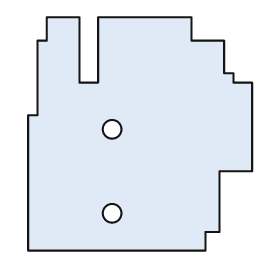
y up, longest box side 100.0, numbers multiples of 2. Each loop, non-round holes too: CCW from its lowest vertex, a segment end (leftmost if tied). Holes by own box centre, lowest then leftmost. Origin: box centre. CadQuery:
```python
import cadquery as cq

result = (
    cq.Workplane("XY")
    .moveTo(-48.0, -50.0)
    .lineTo(28.0, -50.0)
    .lineTo(28.0, -42.0)
    .lineTo(34.0, -42.0)
    .lineTo(34.0, -16.0)
    .lineTo(48.0, -16.0)
    .lineTo(48.0, 22.0)
    .lineTo(40.0, 22.0)
    .lineTo(40.0, 26.0)
    .lineTo(36.0, 26.0)
    .lineTo(36.0, 40.0)
    .lineTo(22.0, 40.0)
    .lineTo(22.0, 50.0)
    .lineTo(-18.0, 50.0)
    .lineTo(-18.0, 22.0)
    .lineTo(-26.0, 22.0)
    .lineTo(-26.0, 50.0)
    .lineTo(-40.0, 50.0)
    .lineTo(-40.0, 40.0)
    .lineTo(-44.0, 40.0)
    .lineTo(-44.0, 8.0)
    .lineTo(-48.0, 8.0)
    .close()
    .moveTo(-12.0, -34.0)
    .circle(4.0)
    .moveTo(-12.0, 2.0)
    .circle(4.0)
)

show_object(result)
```